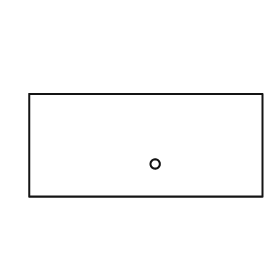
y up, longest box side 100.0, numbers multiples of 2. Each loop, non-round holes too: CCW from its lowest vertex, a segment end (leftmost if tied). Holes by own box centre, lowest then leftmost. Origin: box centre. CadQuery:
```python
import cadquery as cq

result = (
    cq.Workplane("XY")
    .moveTo(-50.0, -22.0)
    .lineTo(50.0, -22.0)
    .lineTo(50.0, 22.0)
    .lineTo(-50.0, 22.0)
    .close()
    .moveTo(4.0, -8.0)
    .circle(2.0)
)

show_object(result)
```